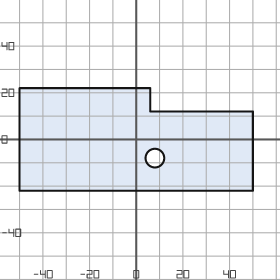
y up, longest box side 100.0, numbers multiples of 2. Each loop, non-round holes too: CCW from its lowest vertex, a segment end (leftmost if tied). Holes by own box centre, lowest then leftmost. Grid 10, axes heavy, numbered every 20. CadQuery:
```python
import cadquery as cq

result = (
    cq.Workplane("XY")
    .moveTo(-50.0, -22.0)
    .lineTo(50.0, -22.0)
    .lineTo(50.0, 12.0)
    .lineTo(6.0, 12.0)
    .lineTo(6.0, 22.0)
    .lineTo(-50.0, 22.0)
    .close()
    .moveTo(8.0, -8.0)
    .circle(4.0)
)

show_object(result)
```